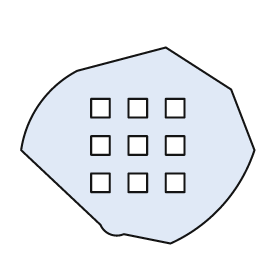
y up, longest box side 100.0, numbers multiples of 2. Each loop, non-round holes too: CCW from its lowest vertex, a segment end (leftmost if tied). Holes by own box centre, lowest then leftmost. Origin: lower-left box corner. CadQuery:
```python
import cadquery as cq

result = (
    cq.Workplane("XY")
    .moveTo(64.0, 0.0)
    .threePointArc((86.0, 16.0), (100.0, 40.0))
    .lineTo(90.0, 66.0)
    .lineTo(62.0, 84.0)
    .lineTo(24.0, 74.0)
    .threePointArc((8.0, 60.0), (0.0, 40.0))
    .lineTo(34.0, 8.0)
    .threePointArc((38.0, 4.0), (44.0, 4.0))
    .close()
    .moveTo(30.0, 22.0)
    .lineTo(38.0, 22.0)
    .lineTo(38.0, 30.0)
    .lineTo(30.0, 30.0)
    .close()
    .moveTo(46.0, 22.0)
    .lineTo(54.0, 22.0)
    .lineTo(54.0, 30.0)
    .lineTo(46.0, 30.0)
    .close()
    .moveTo(62.0, 22.0)
    .lineTo(70.0, 22.0)
    .lineTo(70.0, 30.0)
    .lineTo(62.0, 30.0)
    .close()
    .moveTo(30.0, 38.0)
    .lineTo(38.0, 38.0)
    .lineTo(38.0, 46.0)
    .lineTo(30.0, 46.0)
    .close()
    .moveTo(46.0, 38.0)
    .lineTo(54.0, 38.0)
    .lineTo(54.0, 46.0)
    .lineTo(46.0, 46.0)
    .close()
    .moveTo(62.0, 38.0)
    .lineTo(70.0, 38.0)
    .lineTo(70.0, 46.0)
    .lineTo(62.0, 46.0)
    .close()
    .moveTo(30.0, 54.0)
    .lineTo(38.0, 54.0)
    .lineTo(38.0, 62.0)
    .lineTo(30.0, 62.0)
    .close()
    .moveTo(46.0, 54.0)
    .lineTo(54.0, 54.0)
    .lineTo(54.0, 62.0)
    .lineTo(46.0, 62.0)
    .close()
    .moveTo(62.0, 54.0)
    .lineTo(70.0, 54.0)
    .lineTo(70.0, 62.0)
    .lineTo(62.0, 62.0)
    .close()
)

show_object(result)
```